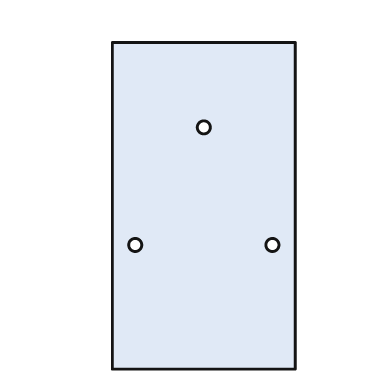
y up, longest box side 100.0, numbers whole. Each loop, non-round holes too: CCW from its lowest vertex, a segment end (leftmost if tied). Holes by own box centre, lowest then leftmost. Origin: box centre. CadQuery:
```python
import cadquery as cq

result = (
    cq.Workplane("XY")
    .moveTo(-28.0, -50.0)
    .lineTo(28.0, -50.0)
    .lineTo(28.0, 50.0)
    .lineTo(-28.0, 50.0)
    .close()
    .moveTo(-21.0, -12.0)
    .circle(2.0)
    .moveTo(21.0, -12.0)
    .circle(2.0)
    .moveTo(0.0, 24.0)
    .circle(2.0)
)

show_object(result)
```